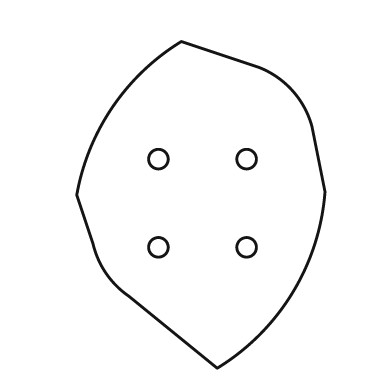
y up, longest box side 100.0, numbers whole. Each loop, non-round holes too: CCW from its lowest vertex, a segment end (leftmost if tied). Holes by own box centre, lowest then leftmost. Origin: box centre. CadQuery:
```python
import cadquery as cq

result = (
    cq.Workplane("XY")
    .moveTo(5.0, -50.0)
    .threePointArc((28.0, -27.0), (38.0, 4.0))
    .lineTo(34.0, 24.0)
    .threePointArc((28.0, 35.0), (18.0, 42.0))
    .lineTo(-6.0, 50.0)
    .threePointArc((-27.0, 30.0), (-38.0, 3.0))
    .lineTo(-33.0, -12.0)
    .threePointArc((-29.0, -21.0), (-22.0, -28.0))
    .close()
    .moveTo(-13.0, -13.0)
    .circle(3.0)
    .moveTo(14.0, -13.0)
    .circle(3.0)
    .moveTo(-13.0, 14.0)
    .circle(3.0)
    .moveTo(14.0, 14.0)
    .circle(3.0)
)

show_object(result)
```